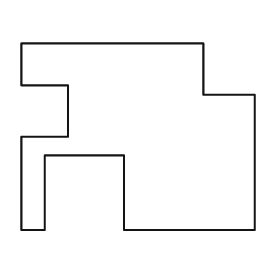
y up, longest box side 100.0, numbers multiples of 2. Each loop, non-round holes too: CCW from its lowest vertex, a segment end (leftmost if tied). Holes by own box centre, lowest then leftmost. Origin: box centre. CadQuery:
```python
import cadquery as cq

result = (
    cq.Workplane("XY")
    .moveTo(-50.0, -40.0)
    .lineTo(-40.0, -40.0)
    .lineTo(-40.0, -8.0)
    .lineTo(-6.0, -8.0)
    .lineTo(-6.0, -40.0)
    .lineTo(50.0, -40.0)
    .lineTo(50.0, 18.0)
    .lineTo(28.0, 18.0)
    .lineTo(28.0, 40.0)
    .lineTo(-50.0, 40.0)
    .lineTo(-50.0, 22.0)
    .lineTo(-30.0, 22.0)
    .lineTo(-30.0, 0.0)
    .lineTo(-50.0, 0.0)
    .close()
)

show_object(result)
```